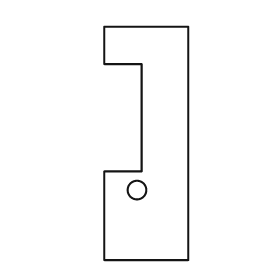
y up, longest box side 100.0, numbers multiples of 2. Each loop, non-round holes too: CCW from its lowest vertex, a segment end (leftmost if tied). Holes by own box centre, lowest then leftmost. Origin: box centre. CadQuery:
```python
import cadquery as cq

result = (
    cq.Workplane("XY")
    .moveTo(-18.0, -50.0)
    .lineTo(18.0, -50.0)
    .lineTo(18.0, 50.0)
    .lineTo(-18.0, 50.0)
    .lineTo(-18.0, 34.0)
    .lineTo(-2.0, 34.0)
    .lineTo(-2.0, -12.0)
    .lineTo(-18.0, -12.0)
    .close()
    .moveTo(-4.0, -20.0)
    .circle(4.0)
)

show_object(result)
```